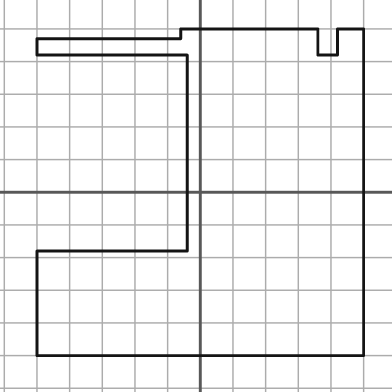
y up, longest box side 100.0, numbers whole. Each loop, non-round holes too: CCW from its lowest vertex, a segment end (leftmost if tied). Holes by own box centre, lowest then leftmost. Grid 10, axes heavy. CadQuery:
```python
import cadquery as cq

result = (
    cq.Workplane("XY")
    .moveTo(-50.0, -50.0)
    .lineTo(50.0, -50.0)
    .lineTo(50.0, 50.0)
    .lineTo(42.0, 50.0)
    .lineTo(42.0, 42.0)
    .lineTo(36.0, 42.0)
    .lineTo(36.0, 50.0)
    .lineTo(-6.0, 50.0)
    .lineTo(-6.0, 47.0)
    .lineTo(-50.0, 47.0)
    .lineTo(-50.0, 42.0)
    .lineTo(-4.0, 42.0)
    .lineTo(-4.0, -18.0)
    .lineTo(-50.0, -18.0)
    .close()
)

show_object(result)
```